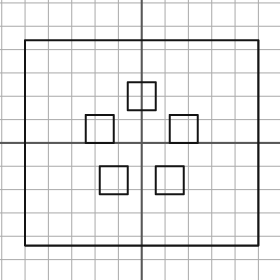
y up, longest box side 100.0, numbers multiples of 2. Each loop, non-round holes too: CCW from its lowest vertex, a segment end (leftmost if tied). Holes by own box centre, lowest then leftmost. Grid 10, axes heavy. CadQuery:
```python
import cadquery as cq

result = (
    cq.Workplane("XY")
    .moveTo(-50.0, -44.0)
    .lineTo(50.0, -44.0)
    .lineTo(50.0, 44.0)
    .lineTo(-50.0, 44.0)
    .close()
    .moveTo(-18.0, -22.0)
    .lineTo(-6.0, -22.0)
    .lineTo(-6.0, -10.0)
    .lineTo(-18.0, -10.0)
    .close()
    .moveTo(6.0, -22.0)
    .lineTo(18.0, -22.0)
    .lineTo(18.0, -10.0)
    .lineTo(6.0, -10.0)
    .close()
    .moveTo(-24.0, 0.0)
    .lineTo(-12.0, 0.0)
    .lineTo(-12.0, 12.0)
    .lineTo(-24.0, 12.0)
    .close()
    .moveTo(12.0, 0.0)
    .lineTo(24.0, 0.0)
    .lineTo(24.0, 12.0)
    .lineTo(12.0, 12.0)
    .close()
    .moveTo(-6.0, 14.0)
    .lineTo(6.0, 14.0)
    .lineTo(6.0, 26.0)
    .lineTo(-6.0, 26.0)
    .close()
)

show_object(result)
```